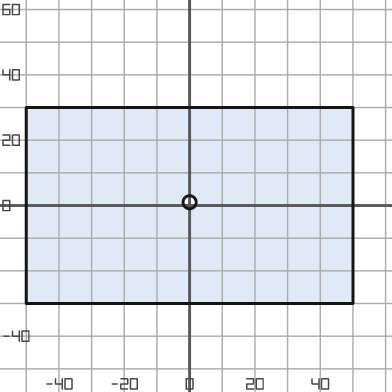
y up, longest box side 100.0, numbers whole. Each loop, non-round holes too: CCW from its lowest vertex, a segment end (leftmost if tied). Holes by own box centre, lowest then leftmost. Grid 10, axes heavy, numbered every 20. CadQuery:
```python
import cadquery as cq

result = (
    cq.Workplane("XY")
    .moveTo(-50.0, -30.0)
    .lineTo(50.0, -30.0)
    .lineTo(50.0, 30.0)
    .lineTo(-50.0, 30.0)
    .close()
    .moveTo(0.0, 1.0)
    .circle(2.0)
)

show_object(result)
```